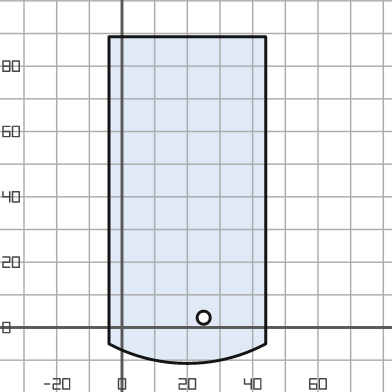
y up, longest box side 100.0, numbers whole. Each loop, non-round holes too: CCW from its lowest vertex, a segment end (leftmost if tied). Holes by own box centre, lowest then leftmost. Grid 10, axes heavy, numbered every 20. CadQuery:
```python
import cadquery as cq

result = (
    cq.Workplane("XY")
    .moveTo(-4.0, -5.0)
    .threePointArc((20.0, -11.0), (44.0, -5.0))
    .lineTo(44.0, 89.0)
    .lineTo(-4.0, 89.0)
    .close()
    .moveTo(25.0, 3.0)
    .circle(2.0)
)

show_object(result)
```